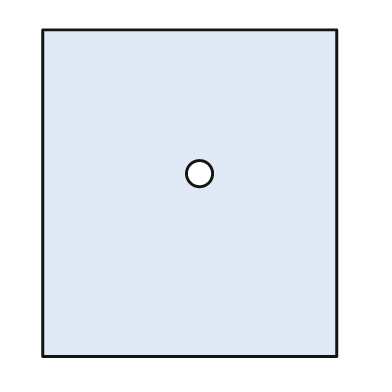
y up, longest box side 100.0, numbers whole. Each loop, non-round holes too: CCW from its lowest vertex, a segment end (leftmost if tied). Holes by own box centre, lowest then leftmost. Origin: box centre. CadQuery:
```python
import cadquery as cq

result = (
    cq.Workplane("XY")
    .moveTo(-45.0, -50.0)
    .lineTo(45.0, -50.0)
    .lineTo(45.0, 50.0)
    .lineTo(-45.0, 50.0)
    .close()
    .moveTo(3.0, 6.0)
    .circle(4.0)
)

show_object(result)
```